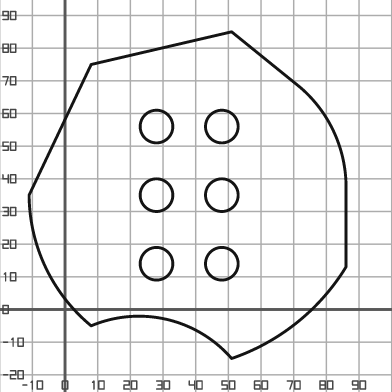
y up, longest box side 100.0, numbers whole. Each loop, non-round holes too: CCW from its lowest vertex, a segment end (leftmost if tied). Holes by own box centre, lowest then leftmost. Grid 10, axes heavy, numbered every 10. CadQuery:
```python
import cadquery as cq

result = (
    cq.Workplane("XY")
    .moveTo(51.0, -15.0)
    .threePointArc((71.0, -4.0), (86.0, 13.0))
    .lineTo(86.0, 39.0)
    .threePointArc((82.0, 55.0), (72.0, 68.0))
    .lineTo(51.0, 85.0)
    .lineTo(8.0, 75.0)
    .lineTo(-11.0, 35.0)
    .threePointArc((-6.0, 13.0), (8.0, -5.0))
    .threePointArc((31.0, -3.0), (51.0, -15.0))
    .close()
    .moveTo(28.0, 14.0)
    .circle(5.0)
    .moveTo(48.0, 14.0)
    .circle(5.0)
    .moveTo(28.0, 35.0)
    .circle(5.0)
    .moveTo(48.0, 35.0)
    .circle(5.0)
    .moveTo(28.0, 56.0)
    .circle(5.0)
    .moveTo(48.0, 56.0)
    .circle(5.0)
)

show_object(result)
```